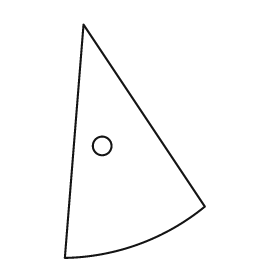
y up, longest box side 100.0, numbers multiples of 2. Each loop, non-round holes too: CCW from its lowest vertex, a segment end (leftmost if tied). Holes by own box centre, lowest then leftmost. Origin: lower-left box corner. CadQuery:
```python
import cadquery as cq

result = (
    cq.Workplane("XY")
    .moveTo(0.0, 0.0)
    .threePointArc((32.0, 6.0), (60.0, 22.0))
    .lineTo(8.0, 100.0)
    .close()
    .moveTo(16.0, 48.0)
    .circle(4.0)
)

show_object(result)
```